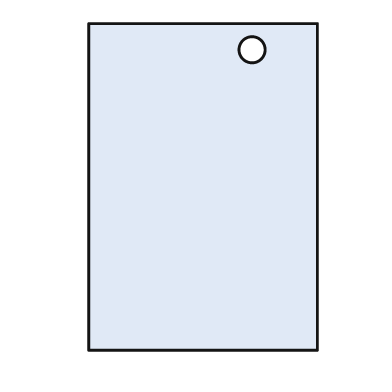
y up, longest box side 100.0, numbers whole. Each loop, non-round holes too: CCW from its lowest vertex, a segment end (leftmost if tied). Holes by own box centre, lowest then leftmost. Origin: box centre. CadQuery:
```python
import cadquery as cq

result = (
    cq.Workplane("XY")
    .moveTo(-35.0, -50.0)
    .lineTo(35.0, -50.0)
    .lineTo(35.0, 50.0)
    .lineTo(-35.0, 50.0)
    .close()
    .moveTo(15.0, 42.0)
    .circle(4.0)
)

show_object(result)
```